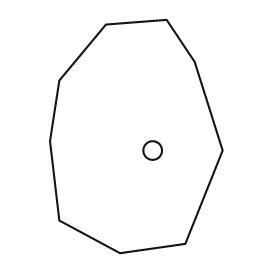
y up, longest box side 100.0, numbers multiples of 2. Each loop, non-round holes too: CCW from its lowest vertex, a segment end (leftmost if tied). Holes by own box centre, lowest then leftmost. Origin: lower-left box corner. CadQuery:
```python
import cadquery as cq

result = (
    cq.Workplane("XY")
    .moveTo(30.0, 0.0)
    .lineTo(58.0, 4.0)
    .lineTo(74.0, 44.0)
    .lineTo(62.0, 82.0)
    .lineTo(50.0, 100.0)
    .lineTo(24.0, 98.0)
    .lineTo(4.0, 74.0)
    .lineTo(0.0, 48.0)
    .lineTo(4.0, 14.0)
    .close()
    .moveTo(44.0, 44.0)
    .circle(4.0)
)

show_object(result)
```